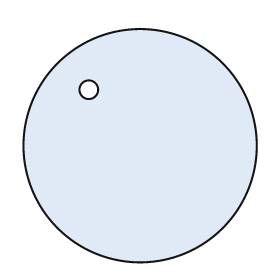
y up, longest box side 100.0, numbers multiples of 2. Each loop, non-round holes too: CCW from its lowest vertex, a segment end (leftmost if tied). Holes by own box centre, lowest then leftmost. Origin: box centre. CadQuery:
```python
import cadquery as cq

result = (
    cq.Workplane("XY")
    .moveTo(0.0, 0.0)
    .circle(50.0)
    .moveTo(-22.0, 24.0)
    .circle(4.0)
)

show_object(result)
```